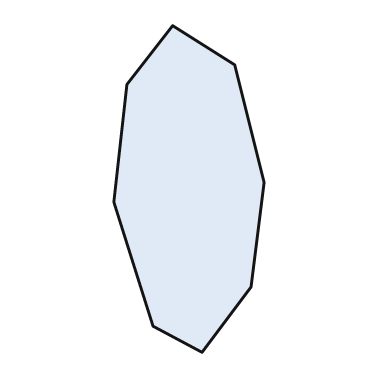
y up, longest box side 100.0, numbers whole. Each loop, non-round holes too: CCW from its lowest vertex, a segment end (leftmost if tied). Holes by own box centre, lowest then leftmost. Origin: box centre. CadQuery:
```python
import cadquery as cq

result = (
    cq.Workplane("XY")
    .moveTo(4.0, -50.0)
    .lineTo(19.0, -30.0)
    .lineTo(23.0, 2.0)
    .lineTo(14.0, 38.0)
    .lineTo(-5.0, 50.0)
    .lineTo(-19.0, 32.0)
    .lineTo(-23.0, -4.0)
    .lineTo(-11.0, -42.0)
    .close()
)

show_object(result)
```